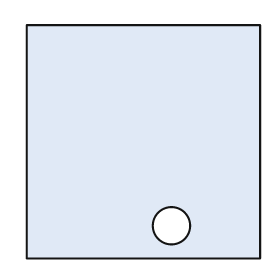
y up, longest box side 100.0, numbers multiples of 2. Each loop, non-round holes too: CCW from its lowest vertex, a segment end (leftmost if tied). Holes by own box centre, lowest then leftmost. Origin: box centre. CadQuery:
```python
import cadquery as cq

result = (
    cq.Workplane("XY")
    .moveTo(-50.0, -50.0)
    .lineTo(50.0, -50.0)
    .lineTo(50.0, 50.0)
    .lineTo(-50.0, 50.0)
    .close()
    .moveTo(12.0, -36.0)
    .circle(8.0)
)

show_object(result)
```